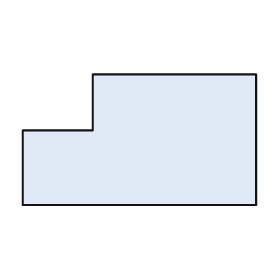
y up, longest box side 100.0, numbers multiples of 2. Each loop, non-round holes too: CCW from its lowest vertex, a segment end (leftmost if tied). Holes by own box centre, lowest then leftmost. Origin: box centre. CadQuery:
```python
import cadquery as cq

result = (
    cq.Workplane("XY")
    .moveTo(-50.0, -28.0)
    .lineTo(50.0, -28.0)
    .lineTo(50.0, 28.0)
    .lineTo(-20.0, 28.0)
    .lineTo(-20.0, 4.0)
    .lineTo(-50.0, 4.0)
    .close()
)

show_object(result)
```